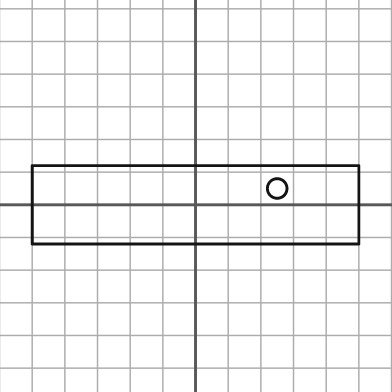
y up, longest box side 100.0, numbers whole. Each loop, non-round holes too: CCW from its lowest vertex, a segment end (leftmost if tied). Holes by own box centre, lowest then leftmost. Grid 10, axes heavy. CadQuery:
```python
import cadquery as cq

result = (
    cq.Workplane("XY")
    .moveTo(-50.0, -12.0)
    .lineTo(50.0, -12.0)
    .lineTo(50.0, 12.0)
    .lineTo(-50.0, 12.0)
    .close()
    .moveTo(25.0, 5.0)
    .circle(3.0)
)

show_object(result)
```